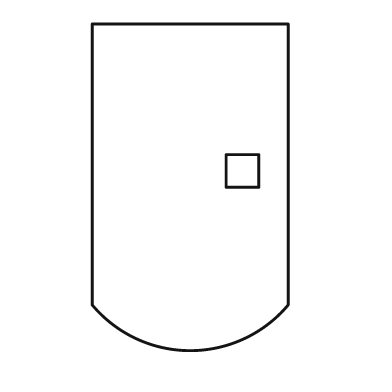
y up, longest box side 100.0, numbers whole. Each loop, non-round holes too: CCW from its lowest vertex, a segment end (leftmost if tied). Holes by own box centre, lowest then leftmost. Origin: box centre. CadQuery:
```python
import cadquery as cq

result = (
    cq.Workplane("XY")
    .moveTo(-30.0, -36.0)
    .threePointArc((0.0, -50.0), (30.0, -36.0))
    .lineTo(30.0, 50.0)
    .lineTo(-30.0, 50.0)
    .close()
    .moveTo(11.0, 0.0)
    .lineTo(21.0, 0.0)
    .lineTo(21.0, 10.0)
    .lineTo(11.0, 10.0)
    .close()
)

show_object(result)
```